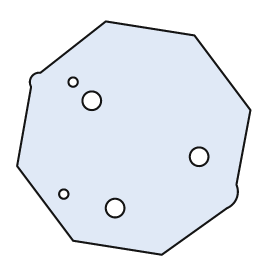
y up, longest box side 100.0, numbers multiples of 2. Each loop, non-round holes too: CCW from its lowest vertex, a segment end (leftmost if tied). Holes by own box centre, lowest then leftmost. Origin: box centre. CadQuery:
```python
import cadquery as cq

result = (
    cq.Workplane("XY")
    .moveTo(12.0, -50.0)
    .lineTo(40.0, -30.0)
    .threePointArc((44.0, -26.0), (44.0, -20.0))
    .lineTo(50.0, 12.0)
    .lineTo(26.0, 44.0)
    .lineTo(-12.0, 50.0)
    .lineTo(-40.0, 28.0)
    .threePointArc((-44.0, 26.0), (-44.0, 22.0))
    .lineTo(-50.0, -12.0)
    .lineTo(-26.0, -44.0)
    .close()
    .moveTo(-8.0, -30.0)
    .circle(4.0)
    .moveTo(-30.0, -24.0)
    .circle(2.0)
    .moveTo(28.0, -8.0)
    .circle(4.0)
    .moveTo(-18.0, 16.0)
    .circle(4.0)
    .moveTo(-26.0, 24.0)
    .circle(2.0)
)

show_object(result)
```